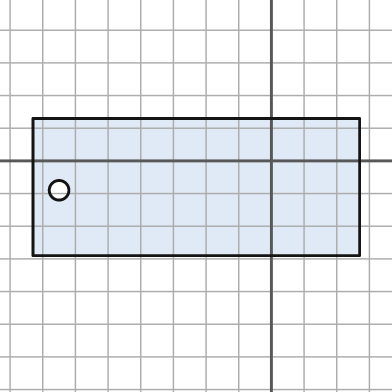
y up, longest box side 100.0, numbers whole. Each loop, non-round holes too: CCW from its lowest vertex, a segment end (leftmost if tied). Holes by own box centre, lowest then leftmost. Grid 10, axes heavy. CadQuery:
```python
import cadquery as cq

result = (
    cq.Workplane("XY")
    .moveTo(-73.0, -29.0)
    .lineTo(27.0, -29.0)
    .lineTo(27.0, 13.0)
    .lineTo(-73.0, 13.0)
    .close()
    .moveTo(-65.0, -9.0)
    .circle(3.0)
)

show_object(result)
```